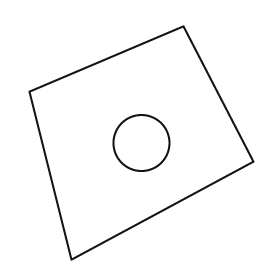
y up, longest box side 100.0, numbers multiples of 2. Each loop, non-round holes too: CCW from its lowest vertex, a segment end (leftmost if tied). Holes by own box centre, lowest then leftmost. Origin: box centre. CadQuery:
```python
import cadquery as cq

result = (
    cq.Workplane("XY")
    .moveTo(-30.0, -50.0)
    .lineTo(48.0, -8.0)
    .lineTo(18.0, 50.0)
    .lineTo(-48.0, 22.0)
    .close()
    .moveTo(0.0, 0.0)
    .circle(12.0)
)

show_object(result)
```